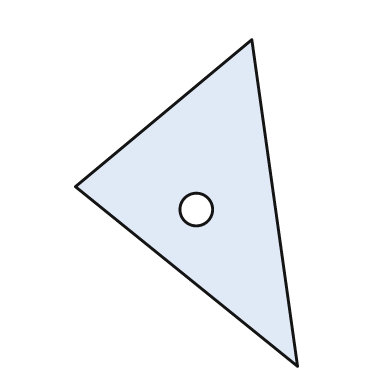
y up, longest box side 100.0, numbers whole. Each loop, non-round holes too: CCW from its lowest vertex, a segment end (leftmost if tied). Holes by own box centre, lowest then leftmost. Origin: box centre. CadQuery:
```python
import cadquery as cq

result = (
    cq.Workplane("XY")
    .moveTo(34.0, -50.0)
    .lineTo(20.0, 50.0)
    .lineTo(-34.0, 5.0)
    .close()
    .moveTo(3.0, -2.0)
    .circle(5.0)
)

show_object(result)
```